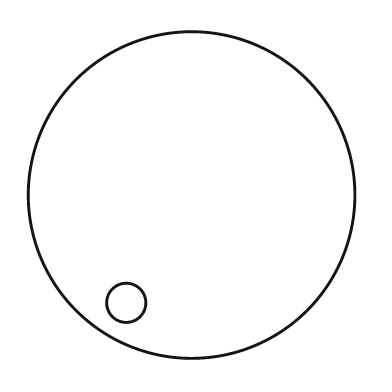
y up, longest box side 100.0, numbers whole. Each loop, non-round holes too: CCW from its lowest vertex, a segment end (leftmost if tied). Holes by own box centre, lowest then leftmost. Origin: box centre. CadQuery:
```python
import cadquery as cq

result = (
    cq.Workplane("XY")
    .moveTo(0.0, 0.0)
    .circle(50.0)
    .moveTo(-20.0, -33.0)
    .circle(6.0)
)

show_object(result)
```